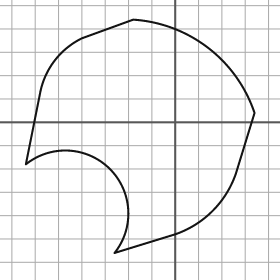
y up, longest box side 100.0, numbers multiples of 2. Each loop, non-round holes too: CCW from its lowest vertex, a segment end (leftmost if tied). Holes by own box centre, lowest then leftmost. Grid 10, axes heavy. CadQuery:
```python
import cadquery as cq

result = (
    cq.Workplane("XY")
    .moveTo(-26.0, -56.0)
    .lineTo(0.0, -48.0)
    .threePointArc((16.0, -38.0), (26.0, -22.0))
    .lineTo(34.0, 4.0)
    .threePointArc((14.0, 32.0), (-18.0, 44.0))
    .lineTo(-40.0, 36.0)
    .threePointArc((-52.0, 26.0), (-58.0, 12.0))
    .lineTo(-64.0, -18.0)
    .threePointArc((-28.0, -20.0), (-26.0, -56.0))
    .close()
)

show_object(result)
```